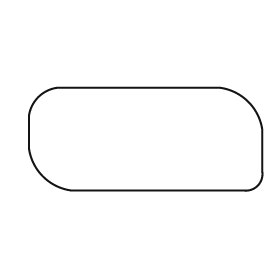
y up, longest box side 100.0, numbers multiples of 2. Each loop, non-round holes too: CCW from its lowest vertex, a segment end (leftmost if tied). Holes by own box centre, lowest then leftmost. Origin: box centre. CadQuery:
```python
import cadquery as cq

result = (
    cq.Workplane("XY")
    .moveTo(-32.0, -22.0)
    .lineTo(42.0, -22.0)
    .threePointArc((48.0, -20.0), (50.0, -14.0))
    .lineTo(50.0, 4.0)
    .threePointArc((44.0, 16.0), (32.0, 22.0))
    .lineTo(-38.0, 22.0)
    .threePointArc((-46.0, 18.0), (-50.0, 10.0))
    .lineTo(-50.0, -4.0)
    .threePointArc((-44.0, -16.0), (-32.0, -22.0))
    .close()
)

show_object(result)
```